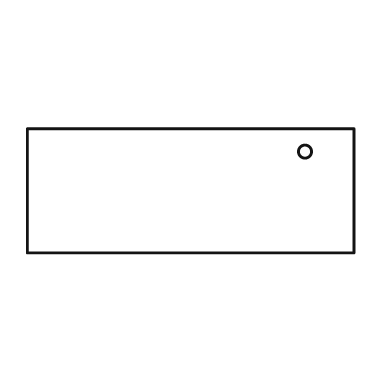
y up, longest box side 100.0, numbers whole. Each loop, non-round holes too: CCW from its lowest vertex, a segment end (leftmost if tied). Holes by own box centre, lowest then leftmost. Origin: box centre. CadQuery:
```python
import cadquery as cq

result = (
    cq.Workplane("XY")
    .moveTo(-50.0, -19.0)
    .lineTo(50.0, -19.0)
    .lineTo(50.0, 19.0)
    .lineTo(-50.0, 19.0)
    .close()
    .moveTo(35.0, 12.0)
    .circle(2.0)
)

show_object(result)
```